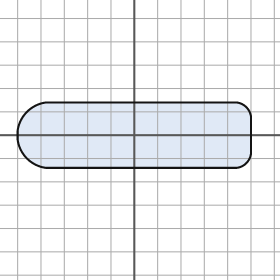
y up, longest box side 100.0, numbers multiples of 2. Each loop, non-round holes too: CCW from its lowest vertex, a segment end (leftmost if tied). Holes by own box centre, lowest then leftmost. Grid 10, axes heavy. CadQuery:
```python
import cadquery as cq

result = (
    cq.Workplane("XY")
    .moveTo(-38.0, -14.0)
    .lineTo(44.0, -14.0)
    .threePointArc((48.0, -12.0), (50.0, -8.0))
    .lineTo(50.0, 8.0)
    .threePointArc((48.0, 12.0), (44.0, 14.0))
    .lineTo(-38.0, 14.0)
    .threePointArc((-46.0, 10.0), (-50.0, 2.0))
    .lineTo(-50.0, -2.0)
    .threePointArc((-46.0, -10.0), (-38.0, -14.0))
    .close()
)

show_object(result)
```